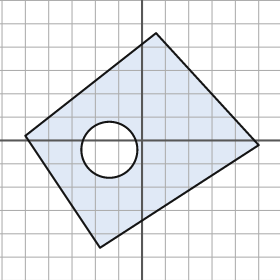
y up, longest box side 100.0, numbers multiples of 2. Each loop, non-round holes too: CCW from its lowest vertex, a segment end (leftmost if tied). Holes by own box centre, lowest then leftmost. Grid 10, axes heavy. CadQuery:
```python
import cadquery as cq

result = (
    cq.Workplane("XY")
    .moveTo(-18.0, -46.0)
    .lineTo(50.0, -2.0)
    .lineTo(6.0, 46.0)
    .lineTo(-50.0, 2.0)
    .close()
    .moveTo(-14.0, -4.0)
    .circle(12.0)
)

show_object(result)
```